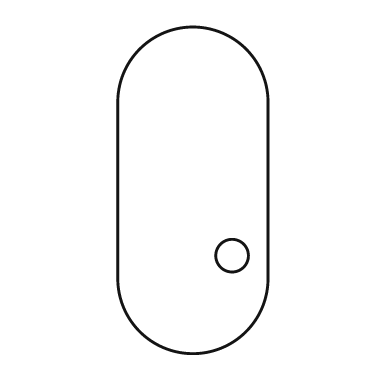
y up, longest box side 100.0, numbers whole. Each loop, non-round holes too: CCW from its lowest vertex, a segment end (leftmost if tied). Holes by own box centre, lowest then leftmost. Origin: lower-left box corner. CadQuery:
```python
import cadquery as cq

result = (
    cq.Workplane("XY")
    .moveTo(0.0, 23.0)
    .threePointArc((23.0, 0.0), (46.0, 23.0))
    .lineTo(46.0, 77.0)
    .threePointArc((23.0, 100.0), (0.0, 77.0))
    .close()
    .moveTo(35.0, 30.0)
    .circle(5.0)
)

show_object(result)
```